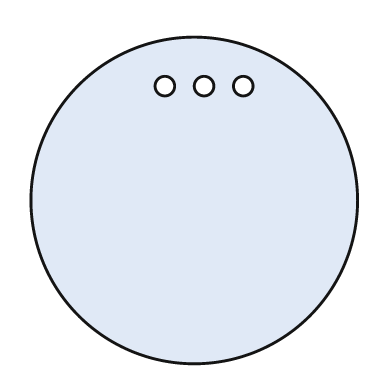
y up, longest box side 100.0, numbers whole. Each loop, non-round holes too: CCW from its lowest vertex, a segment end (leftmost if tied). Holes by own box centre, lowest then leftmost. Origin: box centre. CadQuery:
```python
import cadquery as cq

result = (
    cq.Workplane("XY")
    .moveTo(0.0, 0.0)
    .circle(50.0)
    .moveTo(-9.0, 35.0)
    .circle(3.0)
    .moveTo(3.0, 35.0)
    .circle(3.0)
    .moveTo(15.0, 35.0)
    .circle(3.0)
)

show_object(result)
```